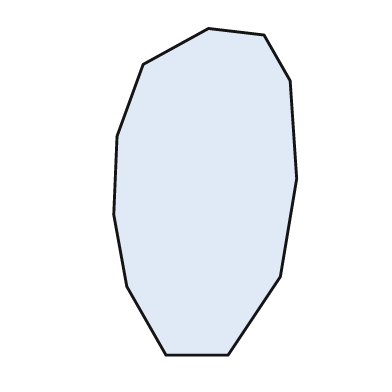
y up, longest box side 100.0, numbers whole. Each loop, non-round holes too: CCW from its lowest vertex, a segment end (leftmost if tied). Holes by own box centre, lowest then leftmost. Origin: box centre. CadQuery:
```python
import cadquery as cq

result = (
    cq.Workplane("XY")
    .moveTo(-12.0, -50.0)
    .lineTo(7.0, -50.0)
    .lineTo(23.0, -26.0)
    .lineTo(28.0, 4.0)
    .lineTo(26.0, 34.0)
    .lineTo(18.0, 48.0)
    .lineTo(1.0, 50.0)
    .lineTo(-19.0, 39.0)
    .lineTo(-27.0, 17.0)
    .lineTo(-28.0, -7.0)
    .lineTo(-24.0, -29.0)
    .close()
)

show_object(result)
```